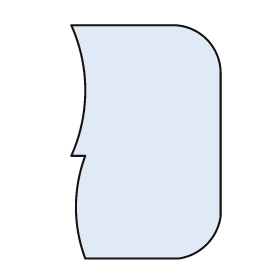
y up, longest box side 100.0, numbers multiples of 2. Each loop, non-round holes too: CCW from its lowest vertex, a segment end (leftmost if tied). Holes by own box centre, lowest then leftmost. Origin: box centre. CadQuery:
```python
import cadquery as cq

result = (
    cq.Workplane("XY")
    .moveTo(-26.0, -50.0)
    .lineTo(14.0, -50.0)
    .threePointArc((26.0, -44.0), (32.0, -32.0))
    .lineTo(32.0, 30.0)
    .threePointArc((26.0, 44.0), (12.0, 50.0))
    .lineTo(-32.0, 50.0)
    .threePointArc((-26.0, 22.0), (-32.0, -6.0))
    .lineTo(-26.0, -6.0)
    .threePointArc((-30.0, -28.0), (-26.0, -50.0))
    .close()
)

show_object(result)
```